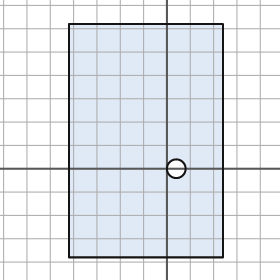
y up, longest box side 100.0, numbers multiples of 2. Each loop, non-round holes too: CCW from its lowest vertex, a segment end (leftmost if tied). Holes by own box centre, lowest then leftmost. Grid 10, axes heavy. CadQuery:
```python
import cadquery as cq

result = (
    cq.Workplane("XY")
    .moveTo(-42.0, -38.0)
    .lineTo(24.0, -38.0)
    .lineTo(24.0, 62.0)
    .lineTo(-42.0, 62.0)
    .close()
    .moveTo(4.0, 0.0)
    .circle(4.0)
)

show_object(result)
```